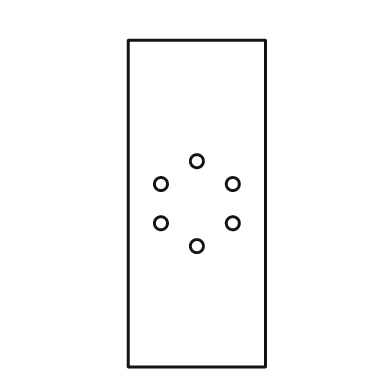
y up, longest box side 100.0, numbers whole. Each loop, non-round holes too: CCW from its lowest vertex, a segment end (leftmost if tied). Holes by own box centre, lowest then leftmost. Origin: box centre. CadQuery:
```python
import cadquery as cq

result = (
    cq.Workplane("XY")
    .moveTo(-21.0, -50.0)
    .lineTo(21.0, -50.0)
    .lineTo(21.0, 50.0)
    .lineTo(-21.0, 50.0)
    .close()
    .moveTo(0.0, -13.0)
    .circle(2.0)
    .moveTo(-11.0, -6.0)
    .circle(2.0)
    .moveTo(11.0, -6.0)
    .circle(2.0)
    .moveTo(-11.0, 6.0)
    .circle(2.0)
    .moveTo(11.0, 6.0)
    .circle(2.0)
    .moveTo(0.0, 13.0)
    .circle(2.0)
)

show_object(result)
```